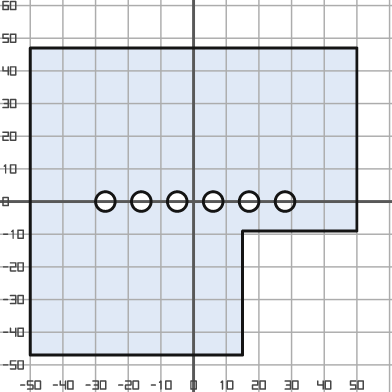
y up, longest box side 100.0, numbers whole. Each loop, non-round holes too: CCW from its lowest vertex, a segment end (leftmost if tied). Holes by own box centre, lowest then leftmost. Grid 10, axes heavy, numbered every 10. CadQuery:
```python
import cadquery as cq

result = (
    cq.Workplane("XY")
    .moveTo(-50.0, -47.0)
    .lineTo(15.0, -47.0)
    .lineTo(15.0, -9.0)
    .lineTo(50.0, -9.0)
    .lineTo(50.0, 47.0)
    .lineTo(-50.0, 47.0)
    .close()
    .moveTo(-27.0, 0.0)
    .circle(3.0)
    .moveTo(-16.0, 0.0)
    .circle(3.0)
    .moveTo(-5.0, 0.0)
    .circle(3.0)
    .moveTo(6.0, 0.0)
    .circle(3.0)
    .moveTo(17.0, 0.0)
    .circle(3.0)
    .moveTo(28.0, 0.0)
    .circle(3.0)
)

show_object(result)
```